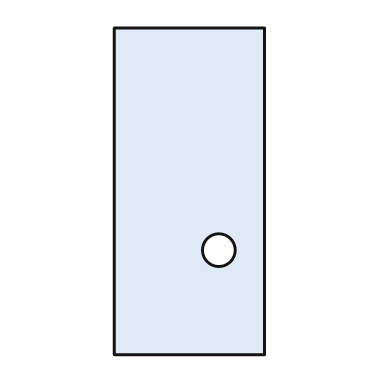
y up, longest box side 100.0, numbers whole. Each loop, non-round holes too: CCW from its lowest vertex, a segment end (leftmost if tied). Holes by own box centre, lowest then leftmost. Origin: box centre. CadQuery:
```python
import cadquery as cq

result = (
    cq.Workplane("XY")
    .moveTo(-23.0, -50.0)
    .lineTo(23.0, -50.0)
    .lineTo(23.0, 50.0)
    .lineTo(-23.0, 50.0)
    .close()
    .moveTo(9.0, -18.0)
    .circle(5.0)
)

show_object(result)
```